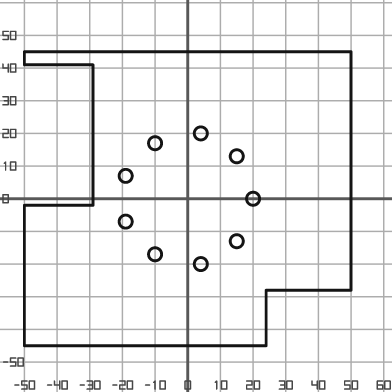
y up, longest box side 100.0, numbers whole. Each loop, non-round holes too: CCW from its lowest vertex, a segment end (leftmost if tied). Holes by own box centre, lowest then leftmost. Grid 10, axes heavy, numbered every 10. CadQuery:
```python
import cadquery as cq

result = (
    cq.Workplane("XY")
    .moveTo(-50.0, -45.0)
    .lineTo(24.0, -45.0)
    .lineTo(24.0, -28.0)
    .lineTo(50.0, -28.0)
    .lineTo(50.0, 45.0)
    .lineTo(-50.0, 45.0)
    .lineTo(-50.0, 41.0)
    .lineTo(-29.0, 41.0)
    .lineTo(-29.0, -2.0)
    .lineTo(-50.0, -2.0)
    .close()
    .moveTo(4.0, -20.0)
    .circle(2.0)
    .moveTo(-10.0, -17.0)
    .circle(2.0)
    .moveTo(15.0, -13.0)
    .circle(2.0)
    .moveTo(-19.0, -7.0)
    .circle(2.0)
    .moveTo(20.0, 0.0)
    .circle(2.0)
    .moveTo(-19.0, 7.0)
    .circle(2.0)
    .moveTo(15.0, 13.0)
    .circle(2.0)
    .moveTo(-10.0, 17.0)
    .circle(2.0)
    .moveTo(4.0, 20.0)
    .circle(2.0)
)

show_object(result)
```